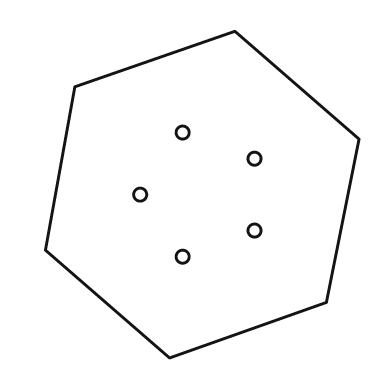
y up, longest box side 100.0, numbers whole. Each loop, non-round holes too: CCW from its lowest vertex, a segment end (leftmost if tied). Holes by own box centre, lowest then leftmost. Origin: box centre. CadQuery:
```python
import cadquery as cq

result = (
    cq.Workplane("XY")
    .moveTo(-10.0, -50.0)
    .lineTo(38.0, -33.0)
    .lineTo(48.0, 17.0)
    .lineTo(10.0, 50.0)
    .lineTo(-39.0, 33.0)
    .lineTo(-48.0, -17.0)
    .close()
    .moveTo(-6.0, -19.0)
    .circle(2.0)
    .moveTo(16.0, -11.0)
    .circle(2.0)
    .moveTo(-19.0, 0.0)
    .circle(2.0)
    .moveTo(16.0, 11.0)
    .circle(2.0)
    .moveTo(-6.0, 19.0)
    .circle(2.0)
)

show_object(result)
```